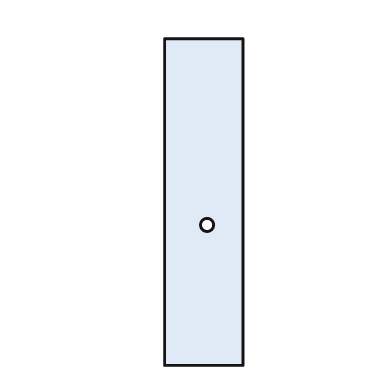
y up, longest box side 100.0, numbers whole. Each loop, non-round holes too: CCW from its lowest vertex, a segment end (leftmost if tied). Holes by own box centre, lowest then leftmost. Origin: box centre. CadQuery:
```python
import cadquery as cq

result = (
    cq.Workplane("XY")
    .moveTo(-12.0, -50.0)
    .lineTo(12.0, -50.0)
    .lineTo(12.0, 50.0)
    .lineTo(-12.0, 50.0)
    .close()
    .moveTo(1.0, -7.0)
    .circle(2.0)
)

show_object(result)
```